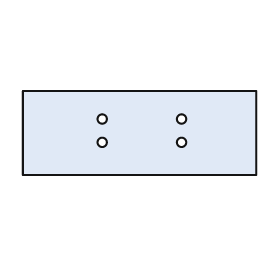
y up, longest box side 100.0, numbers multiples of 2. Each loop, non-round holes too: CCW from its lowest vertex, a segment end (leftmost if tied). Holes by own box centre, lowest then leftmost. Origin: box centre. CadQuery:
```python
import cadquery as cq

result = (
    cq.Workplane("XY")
    .moveTo(-50.0, -18.0)
    .lineTo(50.0, -18.0)
    .lineTo(50.0, 18.0)
    .lineTo(-50.0, 18.0)
    .close()
    .moveTo(-16.0, -4.0)
    .circle(2.0)
    .moveTo(18.0, -4.0)
    .circle(2.0)
    .moveTo(-16.0, 6.0)
    .circle(2.0)
    .moveTo(18.0, 6.0)
    .circle(2.0)
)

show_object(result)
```